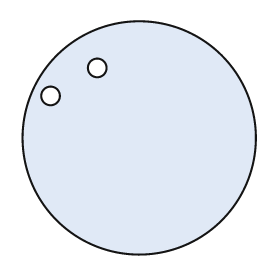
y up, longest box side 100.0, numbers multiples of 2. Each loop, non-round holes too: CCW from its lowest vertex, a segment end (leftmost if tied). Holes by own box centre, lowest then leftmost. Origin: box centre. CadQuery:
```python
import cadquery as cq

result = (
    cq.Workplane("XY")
    .moveTo(0.0, 0.0)
    .circle(50.0)
    .moveTo(-38.0, 18.0)
    .circle(4.0)
    .moveTo(-18.0, 30.0)
    .circle(4.0)
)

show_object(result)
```